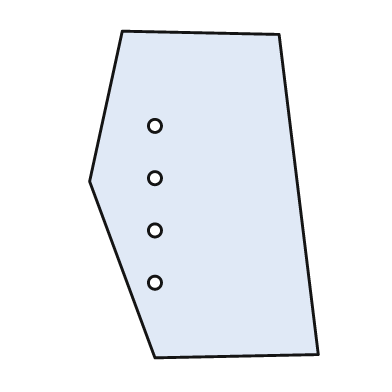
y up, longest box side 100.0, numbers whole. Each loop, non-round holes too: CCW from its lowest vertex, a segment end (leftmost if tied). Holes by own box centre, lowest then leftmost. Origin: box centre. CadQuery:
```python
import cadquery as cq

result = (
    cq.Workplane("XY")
    .moveTo(-15.0, -50.0)
    .lineTo(35.0, -49.0)
    .lineTo(23.0, 49.0)
    .lineTo(-25.0, 50.0)
    .lineTo(-35.0, 4.0)
    .close()
    .moveTo(-15.0, -27.0)
    .circle(2.0)
    .moveTo(-15.0, -11.0)
    .circle(2.0)
    .moveTo(-15.0, 5.0)
    .circle(2.0)
    .moveTo(-15.0, 21.0)
    .circle(2.0)
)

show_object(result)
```